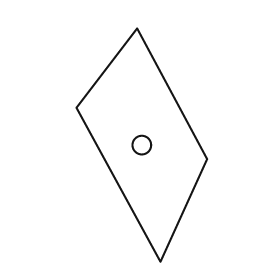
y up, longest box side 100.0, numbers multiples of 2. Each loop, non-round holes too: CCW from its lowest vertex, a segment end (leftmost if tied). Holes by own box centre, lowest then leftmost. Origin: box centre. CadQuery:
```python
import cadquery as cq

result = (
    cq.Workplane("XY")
    .moveTo(8.0, -50.0)
    .lineTo(28.0, -6.0)
    .lineTo(-2.0, 50.0)
    .lineTo(-28.0, 16.0)
    .close()
    .moveTo(0.0, 0.0)
    .circle(4.0)
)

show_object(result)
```